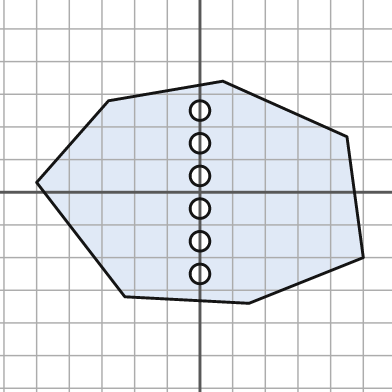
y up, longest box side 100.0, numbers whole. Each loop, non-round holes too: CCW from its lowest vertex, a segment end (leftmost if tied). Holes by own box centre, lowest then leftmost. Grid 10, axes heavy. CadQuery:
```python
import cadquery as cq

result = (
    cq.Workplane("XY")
    .moveTo(15.0, -34.0)
    .lineTo(50.0, -20.0)
    .lineTo(45.0, 17.0)
    .lineTo(7.0, 34.0)
    .lineTo(-28.0, 28.0)
    .lineTo(-50.0, 3.0)
    .lineTo(-23.0, -32.0)
    .close()
    .moveTo(0.0, -25.0)
    .circle(3.0)
    .moveTo(0.0, -15.0)
    .circle(3.0)
    .moveTo(0.0, -5.0)
    .circle(3.0)
    .moveTo(0.0, 5.0)
    .circle(3.0)
    .moveTo(0.0, 15.0)
    .circle(3.0)
    .moveTo(0.0, 25.0)
    .circle(3.0)
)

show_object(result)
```